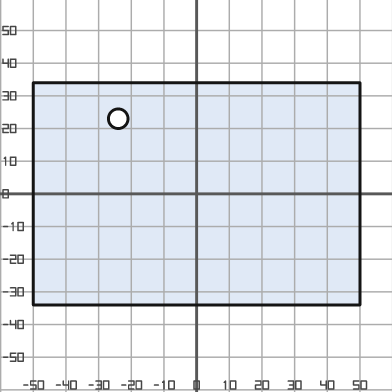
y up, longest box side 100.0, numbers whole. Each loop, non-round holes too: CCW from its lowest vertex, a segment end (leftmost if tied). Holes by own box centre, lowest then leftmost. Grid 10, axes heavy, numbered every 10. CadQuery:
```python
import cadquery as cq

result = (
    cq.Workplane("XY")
    .moveTo(-50.0, -34.0)
    .lineTo(50.0, -34.0)
    .lineTo(50.0, 34.0)
    .lineTo(-50.0, 34.0)
    .close()
    .moveTo(-24.0, 23.0)
    .circle(3.0)
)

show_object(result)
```